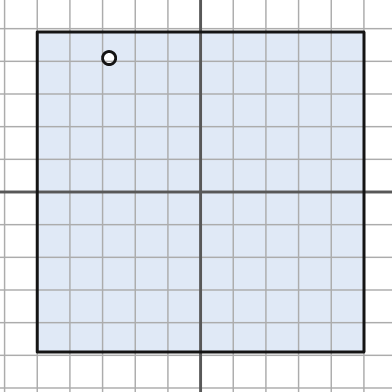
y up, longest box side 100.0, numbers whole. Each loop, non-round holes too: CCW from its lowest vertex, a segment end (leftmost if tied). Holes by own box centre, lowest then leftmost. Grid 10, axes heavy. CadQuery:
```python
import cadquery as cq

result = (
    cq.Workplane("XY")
    .moveTo(-50.0, -49.0)
    .lineTo(50.0, -49.0)
    .lineTo(50.0, 49.0)
    .lineTo(-50.0, 49.0)
    .close()
    .moveTo(-28.0, 41.0)
    .circle(2.0)
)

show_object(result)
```